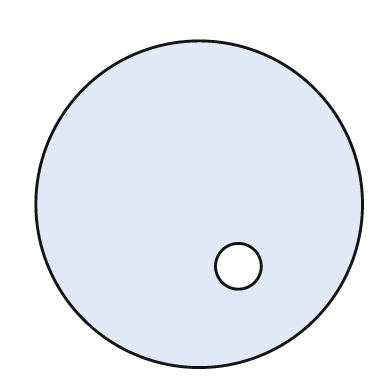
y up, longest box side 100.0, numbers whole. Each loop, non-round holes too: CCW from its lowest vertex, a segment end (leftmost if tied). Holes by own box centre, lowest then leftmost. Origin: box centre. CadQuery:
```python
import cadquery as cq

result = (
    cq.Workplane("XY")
    .moveTo(0.0, 0.0)
    .circle(50.0)
    .moveTo(12.0, -19.0)
    .circle(7.0)
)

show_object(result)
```